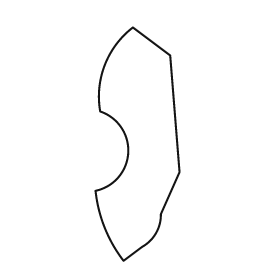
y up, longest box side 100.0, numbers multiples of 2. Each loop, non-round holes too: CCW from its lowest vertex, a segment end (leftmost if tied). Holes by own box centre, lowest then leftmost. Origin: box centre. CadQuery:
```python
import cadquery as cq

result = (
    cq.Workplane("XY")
    .moveTo(-6.0, -50.0)
    .lineTo(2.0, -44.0)
    .threePointArc((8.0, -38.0), (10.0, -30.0))
    .lineTo(18.0, -12.0)
    .lineTo(14.0, 38.0)
    .lineTo(-2.0, 50.0)
    .threePointArc((-14.0, 34.0), (-16.0, 14.0))
    .threePointArc((-4.0, -4.0), (-18.0, -20.0))
    .threePointArc((-14.0, -36.0), (-6.0, -50.0))
    .close()
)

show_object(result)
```